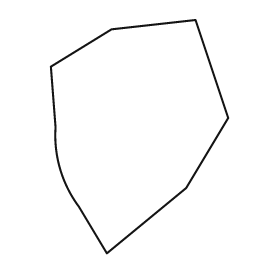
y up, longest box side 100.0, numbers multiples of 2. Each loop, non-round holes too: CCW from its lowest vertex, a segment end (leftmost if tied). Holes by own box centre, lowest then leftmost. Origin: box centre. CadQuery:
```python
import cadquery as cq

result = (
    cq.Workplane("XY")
    .moveTo(-14.0, -50.0)
    .lineTo(20.0, -22.0)
    .lineTo(38.0, 8.0)
    .lineTo(24.0, 50.0)
    .lineTo(-12.0, 46.0)
    .lineTo(-38.0, 30.0)
    .lineTo(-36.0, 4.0)
    .threePointArc((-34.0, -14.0), (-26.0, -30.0))
    .close()
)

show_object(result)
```